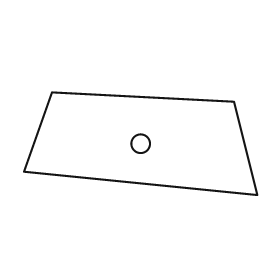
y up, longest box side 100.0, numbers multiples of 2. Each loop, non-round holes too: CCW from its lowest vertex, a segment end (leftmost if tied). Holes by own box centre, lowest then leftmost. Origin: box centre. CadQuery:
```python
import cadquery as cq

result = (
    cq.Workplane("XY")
    .moveTo(50.0, -22.0)
    .lineTo(40.0, 18.0)
    .lineTo(-38.0, 22.0)
    .lineTo(-50.0, -12.0)
    .close()
    .moveTo(0.0, 0.0)
    .circle(4.0)
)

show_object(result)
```